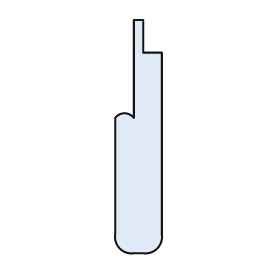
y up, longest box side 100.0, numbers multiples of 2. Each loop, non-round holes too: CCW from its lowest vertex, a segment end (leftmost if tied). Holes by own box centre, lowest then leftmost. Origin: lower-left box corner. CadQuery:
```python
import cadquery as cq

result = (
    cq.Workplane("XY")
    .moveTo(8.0, 0.0)
    .lineTo(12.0, 0.0)
    .threePointArc((18.0, 2.0), (20.0, 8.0))
    .lineTo(20.0, 86.0)
    .lineTo(12.0, 86.0)
    .lineTo(12.0, 100.0)
    .lineTo(8.0, 100.0)
    .lineTo(8.0, 58.0)
    .threePointArc((4.0, 60.0), (0.0, 58.0))
    .lineTo(0.0, 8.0)
    .threePointArc((2.0, 2.0), (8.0, 0.0))
    .close()
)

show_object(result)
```